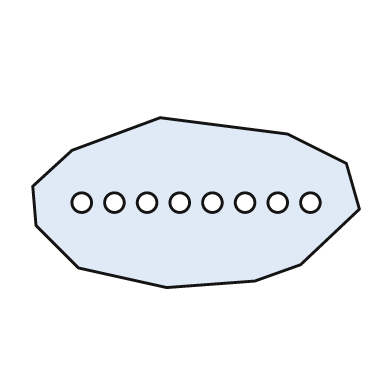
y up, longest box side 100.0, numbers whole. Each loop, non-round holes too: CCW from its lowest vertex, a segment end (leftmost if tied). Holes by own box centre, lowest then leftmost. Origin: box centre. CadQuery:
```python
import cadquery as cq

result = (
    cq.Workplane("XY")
    .moveTo(-9.0, -26.0)
    .lineTo(18.0, -24.0)
    .lineTo(32.0, -19.0)
    .lineTo(50.0, -2.0)
    .lineTo(46.0, 12.0)
    .lineTo(28.0, 21.0)
    .lineTo(-11.0, 26.0)
    .lineTo(-38.0, 16.0)
    .lineTo(-50.0, 5.0)
    .lineTo(-49.0, -7.0)
    .lineTo(-36.0, -20.0)
    .close()
    .moveTo(-35.0, 0.0)
    .circle(3.0)
    .moveTo(-25.0, 0.0)
    .circle(3.0)
    .moveTo(-15.0, 0.0)
    .circle(3.0)
    .moveTo(-5.0, 0.0)
    .circle(3.0)
    .moveTo(5.0, 0.0)
    .circle(3.0)
    .moveTo(15.0, 0.0)
    .circle(3.0)
    .moveTo(25.0, 0.0)
    .circle(3.0)
    .moveTo(35.0, 0.0)
    .circle(3.0)
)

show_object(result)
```